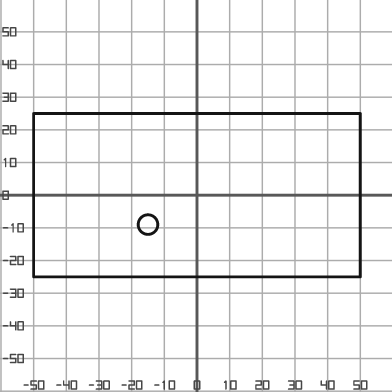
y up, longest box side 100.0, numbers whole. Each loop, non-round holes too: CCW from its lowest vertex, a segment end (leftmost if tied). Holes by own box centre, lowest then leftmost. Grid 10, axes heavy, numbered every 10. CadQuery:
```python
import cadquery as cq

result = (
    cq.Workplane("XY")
    .moveTo(-50.0, -25.0)
    .lineTo(50.0, -25.0)
    .lineTo(50.0, 25.0)
    .lineTo(-50.0, 25.0)
    .close()
    .moveTo(-15.0, -9.0)
    .circle(3.0)
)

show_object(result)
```